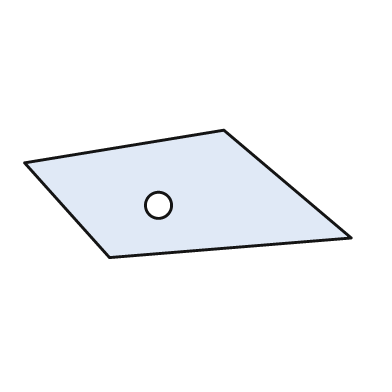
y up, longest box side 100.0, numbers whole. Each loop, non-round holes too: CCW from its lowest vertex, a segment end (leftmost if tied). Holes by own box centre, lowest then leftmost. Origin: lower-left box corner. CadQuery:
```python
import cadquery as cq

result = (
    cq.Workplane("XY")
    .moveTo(26.0, 0.0)
    .lineTo(100.0, 6.0)
    .lineTo(61.0, 39.0)
    .lineTo(0.0, 29.0)
    .close()
    .moveTo(41.0, 16.0)
    .circle(4.0)
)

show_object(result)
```